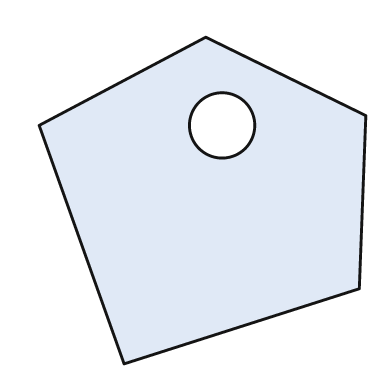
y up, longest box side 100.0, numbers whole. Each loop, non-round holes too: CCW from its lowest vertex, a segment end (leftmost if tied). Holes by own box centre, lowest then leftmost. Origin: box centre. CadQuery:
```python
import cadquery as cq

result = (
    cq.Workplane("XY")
    .moveTo(-24.0, -50.0)
    .lineTo(48.0, -27.0)
    .lineTo(50.0, 26.0)
    .lineTo(1.0, 50.0)
    .lineTo(-50.0, 23.0)
    .close()
    .moveTo(6.0, 23.0)
    .circle(10.0)
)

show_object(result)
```